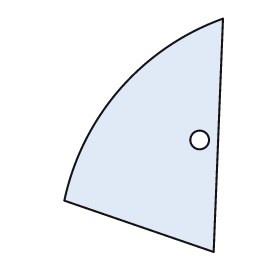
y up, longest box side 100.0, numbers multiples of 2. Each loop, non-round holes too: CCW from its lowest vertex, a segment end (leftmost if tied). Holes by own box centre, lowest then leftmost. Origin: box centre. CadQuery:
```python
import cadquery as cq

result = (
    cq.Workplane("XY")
    .moveTo(30.0, -50.0)
    .lineTo(34.0, 50.0)
    .threePointArc((-10.0, 20.0), (-34.0, -28.0))
    .close()
    .moveTo(24.0, -2.0)
    .circle(4.0)
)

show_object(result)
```